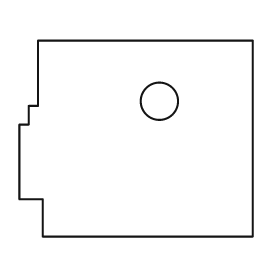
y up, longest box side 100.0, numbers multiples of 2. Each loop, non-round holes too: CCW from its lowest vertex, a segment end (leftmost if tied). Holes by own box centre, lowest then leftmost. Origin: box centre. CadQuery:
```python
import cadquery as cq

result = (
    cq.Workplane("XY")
    .moveTo(-40.0, -42.0)
    .lineTo(50.0, -42.0)
    .lineTo(50.0, 42.0)
    .lineTo(-42.0, 42.0)
    .lineTo(-42.0, 14.0)
    .lineTo(-46.0, 14.0)
    .lineTo(-46.0, 6.0)
    .lineTo(-50.0, 6.0)
    .lineTo(-50.0, -26.0)
    .lineTo(-40.0, -26.0)
    .close()
    .moveTo(10.0, 16.0)
    .circle(8.0)
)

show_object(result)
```